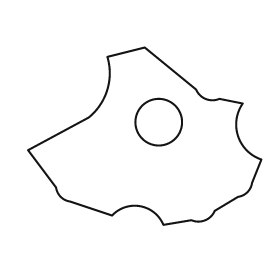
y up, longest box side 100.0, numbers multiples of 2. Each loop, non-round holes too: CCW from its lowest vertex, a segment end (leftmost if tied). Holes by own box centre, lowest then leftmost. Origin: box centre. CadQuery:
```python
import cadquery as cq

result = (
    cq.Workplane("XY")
    .moveTo(8.0, -38.0)
    .lineTo(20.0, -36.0)
    .threePointArc((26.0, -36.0), (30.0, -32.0))
    .lineTo(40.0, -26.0)
    .threePointArc((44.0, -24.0), (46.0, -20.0))
    .lineTo(50.0, -10.0)
    .threePointArc((40.0, 0.0), (42.0, 14.0))
    .lineTo(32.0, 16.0)
    .threePointArc((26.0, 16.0), (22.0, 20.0))
    .lineTo(0.0, 38.0)
    .lineTo(-16.0, 34.0)
    .threePointArc((-16.0, 20.0), (-24.0, 8.0))
    .lineTo(-50.0, -6.0)
    .lineTo(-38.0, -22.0)
    .threePointArc((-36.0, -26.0), (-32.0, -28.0))
    .lineTo(-14.0, -34.0)
    .threePointArc((-2.0, -30.0), (8.0, -38.0))
    .close()
    .moveTo(6.0, 6.0)
    .circle(10.0)
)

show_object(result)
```